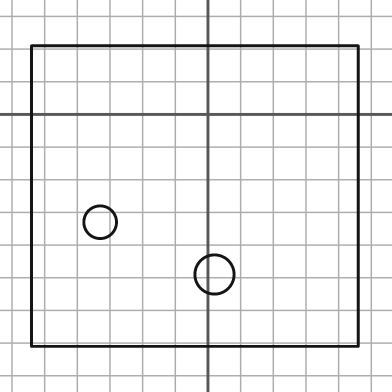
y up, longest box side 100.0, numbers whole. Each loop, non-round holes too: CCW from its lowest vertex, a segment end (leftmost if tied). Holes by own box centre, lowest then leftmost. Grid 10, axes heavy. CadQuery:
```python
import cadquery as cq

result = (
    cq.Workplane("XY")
    .moveTo(-54.0, -71.0)
    .lineTo(46.0, -71.0)
    .lineTo(46.0, 21.0)
    .lineTo(-54.0, 21.0)
    .close()
    .moveTo(2.0, -49.0)
    .circle(6.0)
    .moveTo(-33.0, -33.0)
    .circle(5.0)
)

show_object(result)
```